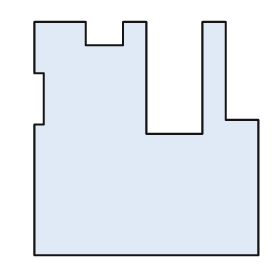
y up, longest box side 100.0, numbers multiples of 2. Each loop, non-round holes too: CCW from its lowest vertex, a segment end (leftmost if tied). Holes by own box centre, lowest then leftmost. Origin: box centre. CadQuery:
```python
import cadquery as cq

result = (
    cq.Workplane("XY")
    .moveTo(-48.0, -50.0)
    .lineTo(48.0, -50.0)
    .lineTo(48.0, 8.0)
    .lineTo(34.0, 8.0)
    .lineTo(34.0, 50.0)
    .lineTo(24.0, 50.0)
    .lineTo(24.0, 2.0)
    .lineTo(0.0, 2.0)
    .lineTo(0.0, 50.0)
    .lineTo(-10.0, 50.0)
    .lineTo(-10.0, 40.0)
    .lineTo(-26.0, 40.0)
    .lineTo(-26.0, 50.0)
    .lineTo(-48.0, 50.0)
    .lineTo(-48.0, 28.0)
    .lineTo(-44.0, 28.0)
    .lineTo(-44.0, 6.0)
    .lineTo(-48.0, 6.0)
    .close()
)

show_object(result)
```